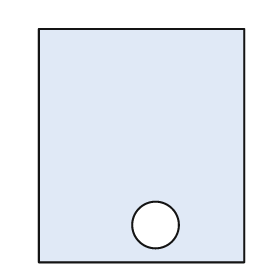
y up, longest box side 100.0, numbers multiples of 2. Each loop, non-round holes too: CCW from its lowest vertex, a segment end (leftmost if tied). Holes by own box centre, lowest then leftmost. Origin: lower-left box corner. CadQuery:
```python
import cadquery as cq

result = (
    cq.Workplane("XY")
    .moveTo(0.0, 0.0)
    .lineTo(88.0, 0.0)
    .lineTo(88.0, 100.0)
    .lineTo(0.0, 100.0)
    .close()
    .moveTo(50.0, 16.0)
    .circle(10.0)
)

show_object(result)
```